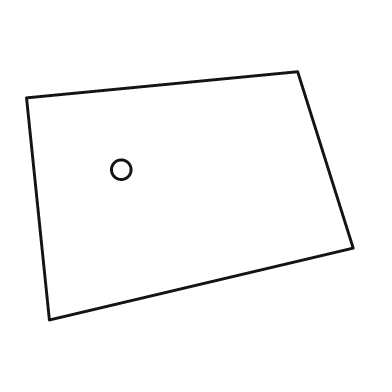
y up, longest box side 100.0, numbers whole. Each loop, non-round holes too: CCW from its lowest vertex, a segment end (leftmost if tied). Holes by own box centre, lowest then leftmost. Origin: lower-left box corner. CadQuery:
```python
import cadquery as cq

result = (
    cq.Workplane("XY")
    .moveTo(7.0, 0.0)
    .lineTo(100.0, 22.0)
    .lineTo(83.0, 76.0)
    .lineTo(0.0, 68.0)
    .close()
    .moveTo(29.0, 46.0)
    .circle(3.0)
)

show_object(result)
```